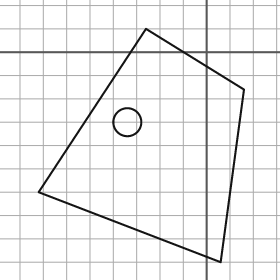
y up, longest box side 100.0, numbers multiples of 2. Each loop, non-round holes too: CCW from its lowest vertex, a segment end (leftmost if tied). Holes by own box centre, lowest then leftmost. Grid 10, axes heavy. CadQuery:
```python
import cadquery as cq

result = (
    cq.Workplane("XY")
    .moveTo(6.0, -90.0)
    .lineTo(16.0, -16.0)
    .lineTo(-26.0, 10.0)
    .lineTo(-72.0, -60.0)
    .close()
    .moveTo(-34.0, -30.0)
    .circle(6.0)
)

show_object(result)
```